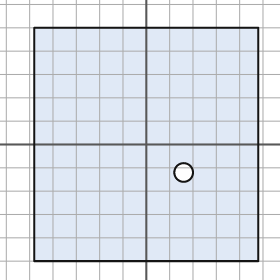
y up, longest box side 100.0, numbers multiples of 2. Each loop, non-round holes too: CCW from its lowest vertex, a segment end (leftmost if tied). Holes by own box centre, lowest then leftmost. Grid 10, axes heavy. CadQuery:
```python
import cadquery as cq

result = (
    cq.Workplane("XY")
    .moveTo(-48.0, -50.0)
    .lineTo(48.0, -50.0)
    .lineTo(48.0, 50.0)
    .lineTo(-48.0, 50.0)
    .close()
    .moveTo(16.0, -12.0)
    .circle(4.0)
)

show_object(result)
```